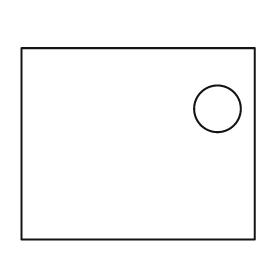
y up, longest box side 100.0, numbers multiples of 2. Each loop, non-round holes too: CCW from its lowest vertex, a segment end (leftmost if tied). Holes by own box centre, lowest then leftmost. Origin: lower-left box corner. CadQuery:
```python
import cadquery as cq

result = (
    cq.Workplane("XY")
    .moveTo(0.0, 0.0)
    .lineTo(100.0, 0.0)
    .lineTo(100.0, 82.0)
    .lineTo(0.0, 82.0)
    .close()
    .moveTo(84.0, 56.0)
    .circle(10.0)
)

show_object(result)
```